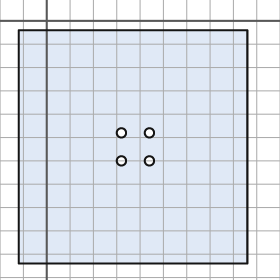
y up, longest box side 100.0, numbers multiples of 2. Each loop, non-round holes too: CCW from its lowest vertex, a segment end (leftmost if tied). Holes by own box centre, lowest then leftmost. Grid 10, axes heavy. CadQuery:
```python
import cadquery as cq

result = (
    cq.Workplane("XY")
    .moveTo(-12.0, -104.0)
    .lineTo(86.0, -104.0)
    .lineTo(86.0, -4.0)
    .lineTo(-12.0, -4.0)
    .close()
    .moveTo(32.0, -60.0)
    .circle(2.0)
    .moveTo(44.0, -60.0)
    .circle(2.0)
    .moveTo(32.0, -48.0)
    .circle(2.0)
    .moveTo(44.0, -48.0)
    .circle(2.0)
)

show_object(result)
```